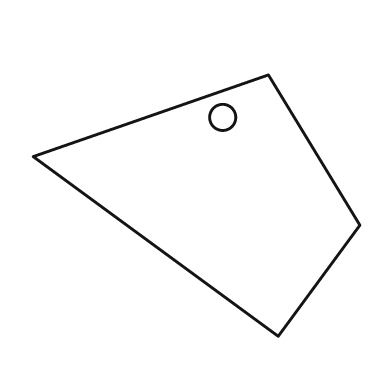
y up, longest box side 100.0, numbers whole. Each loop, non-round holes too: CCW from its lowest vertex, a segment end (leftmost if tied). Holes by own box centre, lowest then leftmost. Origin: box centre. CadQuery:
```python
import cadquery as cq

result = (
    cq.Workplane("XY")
    .moveTo(25.0, -40.0)
    .lineTo(50.0, -6.0)
    .lineTo(22.0, 40.0)
    .lineTo(-50.0, 15.0)
    .close()
    .moveTo(8.0, 27.0)
    .circle(4.0)
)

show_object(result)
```